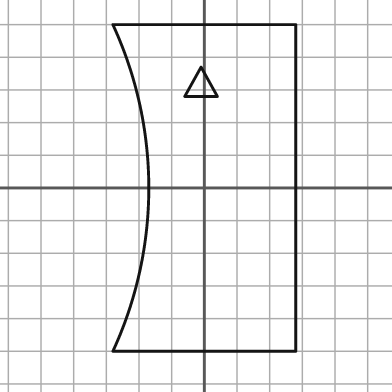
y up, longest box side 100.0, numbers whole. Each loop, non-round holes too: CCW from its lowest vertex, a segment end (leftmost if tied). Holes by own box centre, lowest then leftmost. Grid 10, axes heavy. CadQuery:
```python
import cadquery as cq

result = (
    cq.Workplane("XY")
    .moveTo(-28.0, -50.0)
    .lineTo(28.0, -50.0)
    .lineTo(28.0, 50.0)
    .lineTo(-28.0, 50.0)
    .threePointArc((-17.0, 0.0), (-28.0, -50.0))
    .close()
    .moveTo(-6.0, 28.0)
    .lineTo(4.0, 28.0)
    .lineTo(-1.0, 37.0)
    .close()
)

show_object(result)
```